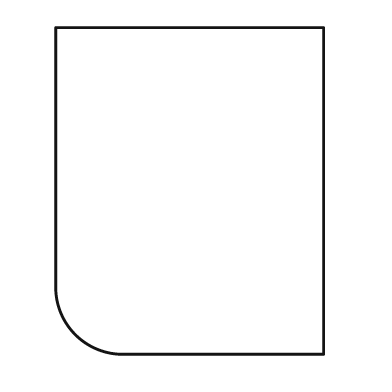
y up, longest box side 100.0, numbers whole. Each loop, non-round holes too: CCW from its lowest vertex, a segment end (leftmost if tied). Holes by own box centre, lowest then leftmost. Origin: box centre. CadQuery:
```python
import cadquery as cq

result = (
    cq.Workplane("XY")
    .moveTo(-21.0, -50.0)
    .lineTo(41.0, -50.0)
    .lineTo(41.0, 50.0)
    .lineTo(-41.0, 50.0)
    .lineTo(-41.0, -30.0)
    .threePointArc((-35.0, -44.0), (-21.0, -50.0))
    .close()
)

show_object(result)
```